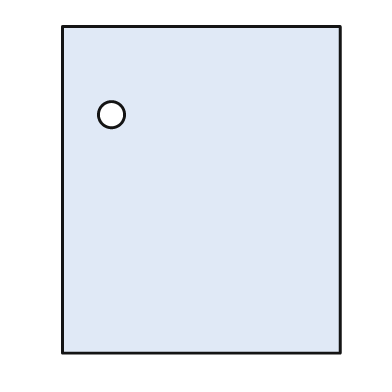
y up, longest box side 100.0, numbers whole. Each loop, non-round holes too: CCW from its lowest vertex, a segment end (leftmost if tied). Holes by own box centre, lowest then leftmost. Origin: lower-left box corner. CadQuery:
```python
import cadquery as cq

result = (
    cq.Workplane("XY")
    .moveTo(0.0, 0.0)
    .lineTo(85.0, 0.0)
    .lineTo(85.0, 100.0)
    .lineTo(0.0, 100.0)
    .close()
    .moveTo(15.0, 73.0)
    .circle(4.0)
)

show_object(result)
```